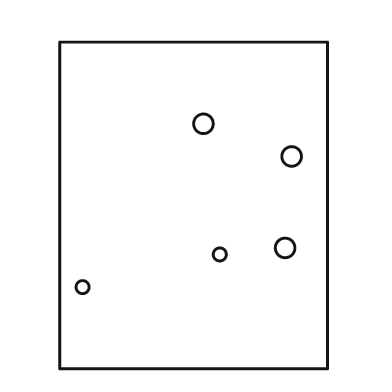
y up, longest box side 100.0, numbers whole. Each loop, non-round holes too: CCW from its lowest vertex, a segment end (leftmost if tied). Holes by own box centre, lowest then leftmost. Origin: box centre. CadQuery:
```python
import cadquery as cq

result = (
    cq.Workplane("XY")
    .moveTo(-41.0, -50.0)
    .lineTo(41.0, -50.0)
    .lineTo(41.0, 50.0)
    .lineTo(-41.0, 50.0)
    .close()
    .moveTo(-34.0, -25.0)
    .circle(2.0)
    .moveTo(8.0, -15.0)
    .circle(2.0)
    .moveTo(28.0, -13.0)
    .circle(3.0)
    .moveTo(30.0, 15.0)
    .circle(3.0)
    .moveTo(3.0, 25.0)
    .circle(3.0)
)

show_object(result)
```